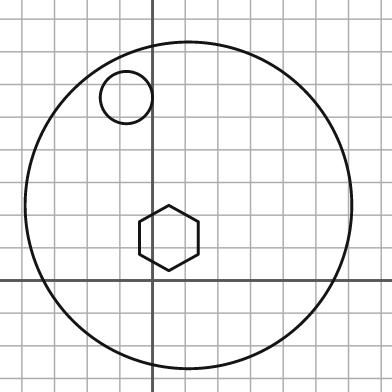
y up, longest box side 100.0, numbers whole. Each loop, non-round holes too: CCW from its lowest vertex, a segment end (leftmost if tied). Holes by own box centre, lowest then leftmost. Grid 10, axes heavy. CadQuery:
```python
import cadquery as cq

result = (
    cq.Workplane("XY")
    .moveTo(11.0, 23.0)
    .circle(50.0)
    .moveTo(5.0, 3.0)
    .lineTo(14.0, 8.0)
    .lineTo(14.0, 18.0)
    .lineTo(5.0, 23.0)
    .lineTo(-4.0, 18.0)
    .lineTo(-4.0, 8.0)
    .close()
    .moveTo(-8.0, 56.0)
    .circle(8.0)
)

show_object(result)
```